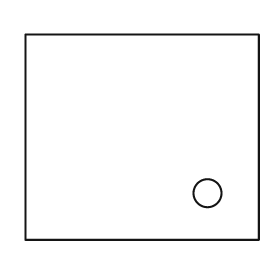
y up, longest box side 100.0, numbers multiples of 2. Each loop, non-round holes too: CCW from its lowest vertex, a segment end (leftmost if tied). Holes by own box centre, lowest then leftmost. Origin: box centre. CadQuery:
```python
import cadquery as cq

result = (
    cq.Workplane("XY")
    .moveTo(-50.0, -44.0)
    .lineTo(50.0, -44.0)
    .lineTo(50.0, 44.0)
    .lineTo(-50.0, 44.0)
    .close()
    .moveTo(28.0, -24.0)
    .circle(6.0)
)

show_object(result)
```